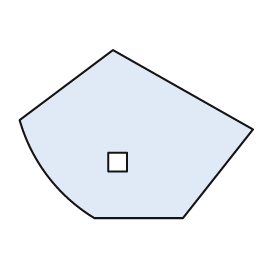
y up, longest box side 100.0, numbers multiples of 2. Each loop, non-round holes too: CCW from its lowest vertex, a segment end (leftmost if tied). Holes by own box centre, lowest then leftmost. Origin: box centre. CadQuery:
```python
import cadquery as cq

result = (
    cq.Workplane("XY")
    .moveTo(-18.0, -36.0)
    .lineTo(20.0, -36.0)
    .lineTo(50.0, 2.0)
    .lineTo(-10.0, 36.0)
    .lineTo(-50.0, 6.0)
    .threePointArc((-38.0, -18.0), (-18.0, -36.0))
    .close()
    .moveTo(-12.0, -16.0)
    .lineTo(-4.0, -16.0)
    .lineTo(-4.0, -8.0)
    .lineTo(-12.0, -8.0)
    .close()
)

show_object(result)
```